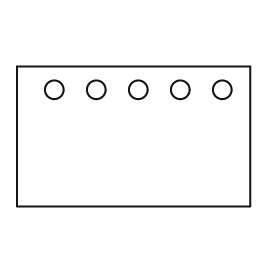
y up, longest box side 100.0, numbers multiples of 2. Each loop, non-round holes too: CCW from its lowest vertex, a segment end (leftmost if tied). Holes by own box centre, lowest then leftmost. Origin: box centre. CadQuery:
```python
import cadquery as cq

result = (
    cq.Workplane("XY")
    .moveTo(-50.0, -30.0)
    .lineTo(50.0, -30.0)
    .lineTo(50.0, 30.0)
    .lineTo(-50.0, 30.0)
    .close()
    .moveTo(-34.0, 20.0)
    .circle(4.0)
    .moveTo(-16.0, 20.0)
    .circle(4.0)
    .moveTo(2.0, 20.0)
    .circle(4.0)
    .moveTo(20.0, 20.0)
    .circle(4.0)
    .moveTo(38.0, 20.0)
    .circle(4.0)
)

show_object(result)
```